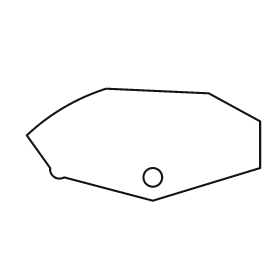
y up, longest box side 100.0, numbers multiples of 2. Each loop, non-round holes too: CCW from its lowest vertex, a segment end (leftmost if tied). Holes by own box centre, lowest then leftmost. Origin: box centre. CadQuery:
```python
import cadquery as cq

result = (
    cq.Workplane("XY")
    .moveTo(4.0, -24.0)
    .lineTo(50.0, -10.0)
    .lineTo(50.0, 10.0)
    .lineTo(28.0, 22.0)
    .lineTo(-16.0, 24.0)
    .threePointArc((-34.0, 16.0), (-50.0, 4.0))
    .lineTo(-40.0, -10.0)
    .threePointArc((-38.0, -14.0), (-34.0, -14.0))
    .close()
    .moveTo(4.0, -14.0)
    .circle(4.0)
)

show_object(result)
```